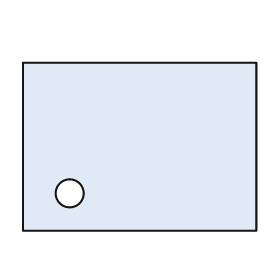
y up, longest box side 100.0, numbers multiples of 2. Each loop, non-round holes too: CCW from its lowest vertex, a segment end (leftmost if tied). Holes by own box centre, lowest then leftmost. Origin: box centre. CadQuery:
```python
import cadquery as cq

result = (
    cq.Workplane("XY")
    .moveTo(-50.0, -36.0)
    .lineTo(50.0, -36.0)
    .lineTo(50.0, 36.0)
    .lineTo(-50.0, 36.0)
    .close()
    .moveTo(-30.0, -20.0)
    .circle(6.0)
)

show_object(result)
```